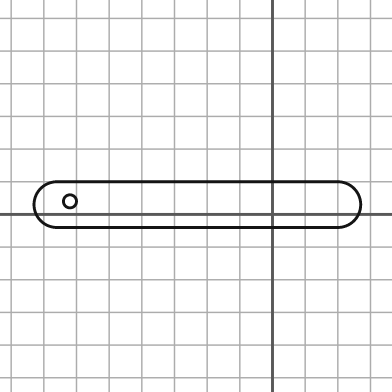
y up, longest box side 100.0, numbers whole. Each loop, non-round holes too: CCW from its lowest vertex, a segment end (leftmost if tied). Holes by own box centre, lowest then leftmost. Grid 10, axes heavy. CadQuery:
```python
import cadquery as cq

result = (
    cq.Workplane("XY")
    .moveTo(-66.0, -4.0)
    .lineTo(20.0, -4.0)
    .threePointArc((27.0, 3.0), (20.0, 10.0))
    .lineTo(-66.0, 10.0)
    .threePointArc((-73.0, 3.0), (-66.0, -4.0))
    .close()
    .moveTo(-62.0, 4.0)
    .circle(2.0)
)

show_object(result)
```